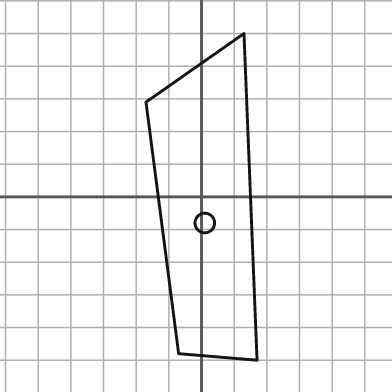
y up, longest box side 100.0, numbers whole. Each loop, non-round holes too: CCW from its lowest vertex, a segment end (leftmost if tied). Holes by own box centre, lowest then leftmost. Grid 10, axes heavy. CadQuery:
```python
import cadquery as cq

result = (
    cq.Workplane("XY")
    .moveTo(17.0, -50.0)
    .lineTo(13.0, 50.0)
    .lineTo(-17.0, 29.0)
    .lineTo(-7.0, -48.0)
    .close()
    .moveTo(1.0, -8.0)
    .circle(3.0)
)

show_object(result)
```